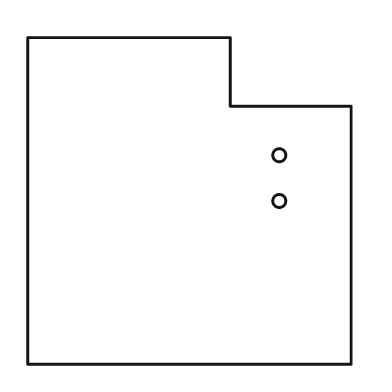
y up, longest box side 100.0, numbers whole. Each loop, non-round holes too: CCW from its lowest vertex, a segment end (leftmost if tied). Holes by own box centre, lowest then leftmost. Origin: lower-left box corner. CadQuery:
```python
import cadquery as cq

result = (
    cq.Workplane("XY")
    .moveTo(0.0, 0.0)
    .lineTo(99.0, 0.0)
    .lineTo(99.0, 79.0)
    .lineTo(62.0, 79.0)
    .lineTo(62.0, 100.0)
    .lineTo(0.0, 100.0)
    .close()
    .moveTo(77.0, 50.0)
    .circle(2.0)
    .moveTo(77.0, 64.0)
    .circle(2.0)
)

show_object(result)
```